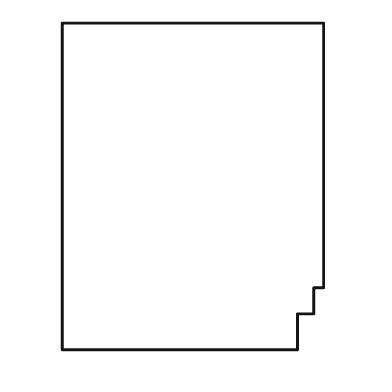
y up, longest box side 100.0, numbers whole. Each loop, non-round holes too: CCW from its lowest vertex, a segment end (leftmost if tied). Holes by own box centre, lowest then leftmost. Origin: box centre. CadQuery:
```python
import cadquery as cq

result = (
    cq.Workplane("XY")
    .moveTo(-40.0, -50.0)
    .lineTo(32.0, -50.0)
    .lineTo(32.0, -39.0)
    .lineTo(37.0, -39.0)
    .lineTo(37.0, -31.0)
    .lineTo(40.0, -31.0)
    .lineTo(40.0, 50.0)
    .lineTo(-40.0, 50.0)
    .close()
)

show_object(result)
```